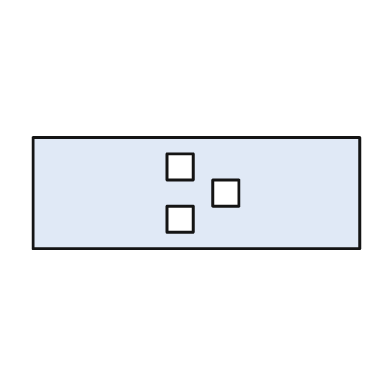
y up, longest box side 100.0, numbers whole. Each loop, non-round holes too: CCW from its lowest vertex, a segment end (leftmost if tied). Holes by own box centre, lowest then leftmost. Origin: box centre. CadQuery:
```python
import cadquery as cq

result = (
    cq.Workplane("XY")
    .moveTo(-50.0, -17.0)
    .lineTo(50.0, -17.0)
    .lineTo(50.0, 17.0)
    .lineTo(-50.0, 17.0)
    .close()
    .moveTo(-9.0, -12.0)
    .lineTo(-1.0, -12.0)
    .lineTo(-1.0, -4.0)
    .lineTo(-9.0, -4.0)
    .close()
    .moveTo(5.0, -4.0)
    .lineTo(13.0, -4.0)
    .lineTo(13.0, 4.0)
    .lineTo(5.0, 4.0)
    .close()
    .moveTo(-9.0, 4.0)
    .lineTo(-1.0, 4.0)
    .lineTo(-1.0, 12.0)
    .lineTo(-9.0, 12.0)
    .close()
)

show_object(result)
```